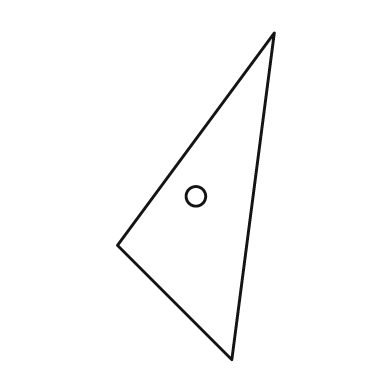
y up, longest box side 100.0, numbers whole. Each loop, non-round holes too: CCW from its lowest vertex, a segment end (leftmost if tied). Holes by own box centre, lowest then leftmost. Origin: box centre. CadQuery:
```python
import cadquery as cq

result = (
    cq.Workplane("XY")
    .moveTo(11.0, -50.0)
    .lineTo(24.0, 50.0)
    .lineTo(-24.0, -15.0)
    .close()
    .moveTo(0.0, 0.0)
    .circle(3.0)
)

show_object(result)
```